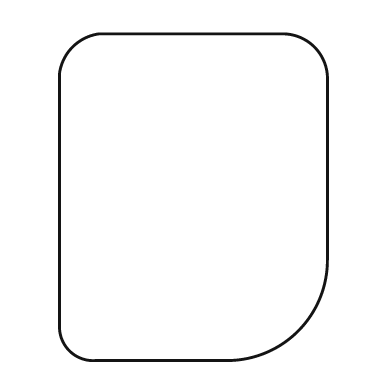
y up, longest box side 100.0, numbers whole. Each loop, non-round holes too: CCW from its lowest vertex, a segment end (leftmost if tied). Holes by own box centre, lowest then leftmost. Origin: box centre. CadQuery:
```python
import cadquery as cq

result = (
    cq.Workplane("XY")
    .moveTo(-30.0, -50.0)
    .lineTo(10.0, -50.0)
    .threePointArc((32.0, -41.0), (41.0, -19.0))
    .lineTo(41.0, 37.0)
    .threePointArc((37.0, 46.0), (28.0, 50.0))
    .lineTo(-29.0, 50.0)
    .threePointArc((-37.0, 46.0), (-41.0, 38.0))
    .lineTo(-41.0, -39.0)
    .threePointArc((-38.0, -47.0), (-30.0, -50.0))
    .close()
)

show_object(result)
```